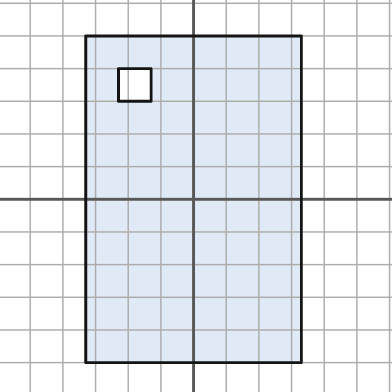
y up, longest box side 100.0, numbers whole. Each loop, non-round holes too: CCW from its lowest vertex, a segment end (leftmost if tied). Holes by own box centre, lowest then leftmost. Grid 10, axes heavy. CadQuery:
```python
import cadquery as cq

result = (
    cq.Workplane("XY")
    .moveTo(-33.0, -50.0)
    .lineTo(33.0, -50.0)
    .lineTo(33.0, 50.0)
    .lineTo(-33.0, 50.0)
    .close()
    .moveTo(-23.0, 30.0)
    .lineTo(-13.0, 30.0)
    .lineTo(-13.0, 40.0)
    .lineTo(-23.0, 40.0)
    .close()
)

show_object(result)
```